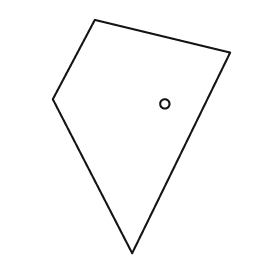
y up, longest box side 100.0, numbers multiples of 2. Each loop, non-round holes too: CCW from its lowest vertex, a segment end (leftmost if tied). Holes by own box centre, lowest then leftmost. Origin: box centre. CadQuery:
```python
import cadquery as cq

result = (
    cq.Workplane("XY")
    .moveTo(-4.0, -50.0)
    .lineTo(38.0, 36.0)
    .lineTo(-20.0, 50.0)
    .lineTo(-38.0, 16.0)
    .close()
    .moveTo(10.0, 14.0)
    .circle(2.0)
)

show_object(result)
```